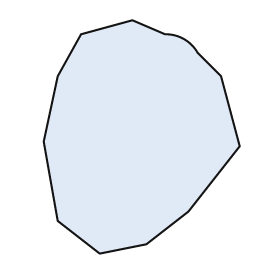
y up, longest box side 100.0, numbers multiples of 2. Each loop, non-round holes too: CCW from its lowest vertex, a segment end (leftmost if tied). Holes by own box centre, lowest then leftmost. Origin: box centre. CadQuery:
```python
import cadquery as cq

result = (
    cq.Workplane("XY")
    .moveTo(-18.0, -50.0)
    .lineTo(2.0, -46.0)
    .lineTo(20.0, -32.0)
    .lineTo(42.0, -4.0)
    .lineTo(34.0, 26.0)
    .lineTo(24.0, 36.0)
    .threePointArc((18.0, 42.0), (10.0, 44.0))
    .lineTo(-4.0, 50.0)
    .lineTo(-26.0, 44.0)
    .lineTo(-36.0, 26.0)
    .lineTo(-42.0, -2.0)
    .lineTo(-36.0, -36.0)
    .close()
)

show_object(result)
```